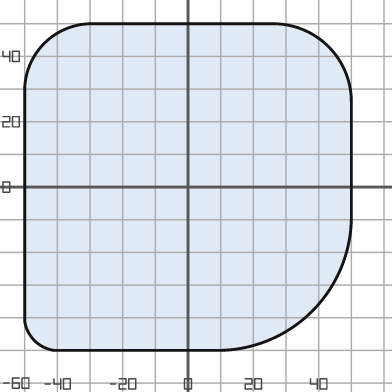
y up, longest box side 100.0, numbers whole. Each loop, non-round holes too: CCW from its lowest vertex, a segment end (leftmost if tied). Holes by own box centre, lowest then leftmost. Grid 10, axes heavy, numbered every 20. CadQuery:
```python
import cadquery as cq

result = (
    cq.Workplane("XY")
    .moveTo(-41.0, -50.0)
    .lineTo(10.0, -50.0)
    .threePointArc((38.0, -38.0), (50.0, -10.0))
    .lineTo(50.0, 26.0)
    .threePointArc((43.0, 43.0), (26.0, 50.0))
    .lineTo(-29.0, 50.0)
    .threePointArc((-44.0, 44.0), (-50.0, 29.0))
    .lineTo(-50.0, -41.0)
    .threePointArc((-47.0, -47.0), (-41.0, -50.0))
    .close()
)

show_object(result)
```